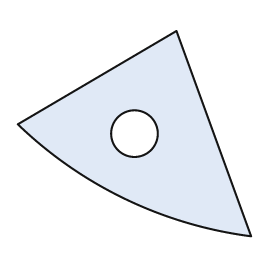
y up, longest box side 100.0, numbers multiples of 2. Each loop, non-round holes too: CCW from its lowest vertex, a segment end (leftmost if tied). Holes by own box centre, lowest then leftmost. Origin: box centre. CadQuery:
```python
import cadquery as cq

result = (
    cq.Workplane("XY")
    .moveTo(50.0, -44.0)
    .lineTo(18.0, 44.0)
    .lineTo(-50.0, 4.0)
    .threePointArc((-4.0, -28.0), (50.0, -44.0))
    .close()
    .moveTo(0.0, 0.0)
    .circle(10.0)
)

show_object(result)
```